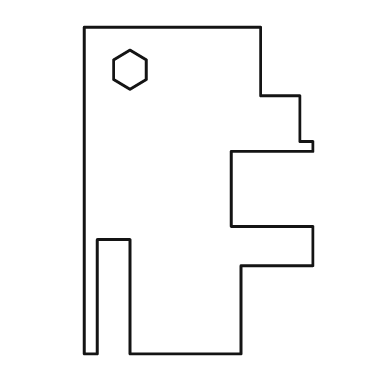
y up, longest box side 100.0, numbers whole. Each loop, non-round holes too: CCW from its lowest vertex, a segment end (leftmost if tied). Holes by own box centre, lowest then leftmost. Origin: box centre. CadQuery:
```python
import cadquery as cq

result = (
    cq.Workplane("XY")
    .moveTo(-35.0, -50.0)
    .lineTo(-31.0, -50.0)
    .lineTo(-31.0, -15.0)
    .lineTo(-21.0, -15.0)
    .lineTo(-21.0, -50.0)
    .lineTo(13.0, -50.0)
    .lineTo(13.0, -23.0)
    .lineTo(35.0, -23.0)
    .lineTo(35.0, -11.0)
    .lineTo(10.0, -11.0)
    .lineTo(10.0, 12.0)
    .lineTo(35.0, 12.0)
    .lineTo(35.0, 15.0)
    .lineTo(31.0, 15.0)
    .lineTo(31.0, 29.0)
    .lineTo(19.0, 29.0)
    .lineTo(19.0, 50.0)
    .lineTo(-35.0, 50.0)
    .close()
    .moveTo(-21.0, 31.0)
    .lineTo(-16.0, 34.0)
    .lineTo(-16.0, 40.0)
    .lineTo(-21.0, 43.0)
    .lineTo(-26.0, 40.0)
    .lineTo(-26.0, 34.0)
    .close()
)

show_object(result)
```